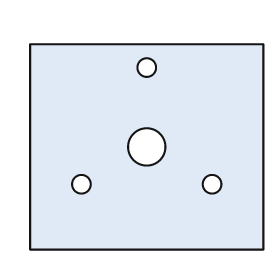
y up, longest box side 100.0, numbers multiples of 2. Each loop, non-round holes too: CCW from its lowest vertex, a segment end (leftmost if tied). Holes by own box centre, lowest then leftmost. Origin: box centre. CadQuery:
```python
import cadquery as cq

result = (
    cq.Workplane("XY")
    .moveTo(-50.0, -44.0)
    .lineTo(50.0, -44.0)
    .lineTo(50.0, 44.0)
    .lineTo(-50.0, 44.0)
    .close()
    .moveTo(-28.0, -16.0)
    .circle(4.0)
    .moveTo(28.0, -16.0)
    .circle(4.0)
    .moveTo(0.0, 0.0)
    .circle(8.0)
    .moveTo(0.0, 34.0)
    .circle(4.0)
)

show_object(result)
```